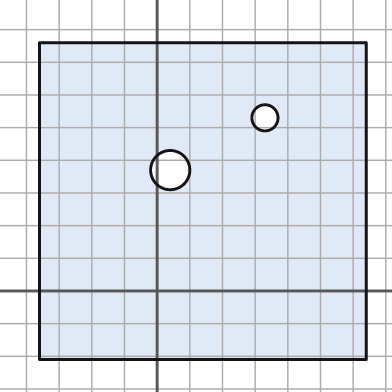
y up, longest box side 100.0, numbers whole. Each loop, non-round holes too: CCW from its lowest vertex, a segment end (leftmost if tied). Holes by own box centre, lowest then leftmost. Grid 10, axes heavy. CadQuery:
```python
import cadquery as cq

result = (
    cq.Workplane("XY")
    .moveTo(-36.0, -21.0)
    .lineTo(64.0, -21.0)
    .lineTo(64.0, 76.0)
    .lineTo(-36.0, 76.0)
    .close()
    .moveTo(4.0, 37.0)
    .circle(6.0)
    .moveTo(33.0, 53.0)
    .circle(4.0)
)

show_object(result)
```